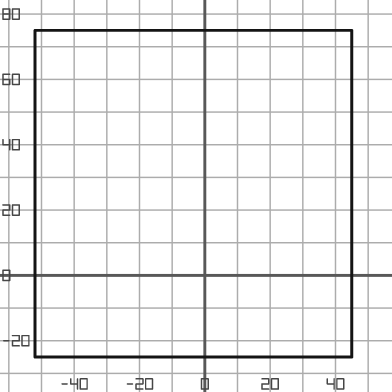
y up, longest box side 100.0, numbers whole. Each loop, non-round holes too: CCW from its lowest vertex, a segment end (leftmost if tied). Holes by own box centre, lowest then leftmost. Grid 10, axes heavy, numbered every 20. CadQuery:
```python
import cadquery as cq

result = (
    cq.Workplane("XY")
    .moveTo(-52.0, -25.0)
    .lineTo(45.0, -25.0)
    .lineTo(45.0, 75.0)
    .lineTo(-52.0, 75.0)
    .close()
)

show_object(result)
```